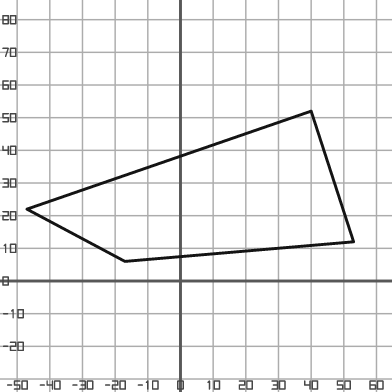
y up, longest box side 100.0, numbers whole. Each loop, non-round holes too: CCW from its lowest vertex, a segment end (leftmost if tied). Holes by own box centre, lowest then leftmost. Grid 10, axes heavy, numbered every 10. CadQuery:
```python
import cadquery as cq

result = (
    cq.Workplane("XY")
    .moveTo(-17.0, 6.0)
    .lineTo(53.0, 12.0)
    .lineTo(40.0, 52.0)
    .lineTo(-47.0, 22.0)
    .close()
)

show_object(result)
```